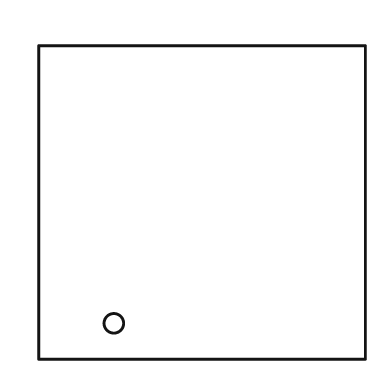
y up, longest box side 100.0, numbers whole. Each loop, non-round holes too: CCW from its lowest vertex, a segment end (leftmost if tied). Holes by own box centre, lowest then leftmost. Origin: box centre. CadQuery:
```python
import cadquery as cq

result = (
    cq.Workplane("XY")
    .moveTo(-50.0, -48.0)
    .lineTo(50.0, -48.0)
    .lineTo(50.0, 48.0)
    .lineTo(-50.0, 48.0)
    .close()
    .moveTo(-27.0, -37.0)
    .circle(3.0)
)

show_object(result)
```